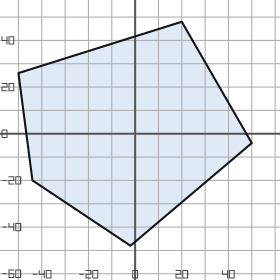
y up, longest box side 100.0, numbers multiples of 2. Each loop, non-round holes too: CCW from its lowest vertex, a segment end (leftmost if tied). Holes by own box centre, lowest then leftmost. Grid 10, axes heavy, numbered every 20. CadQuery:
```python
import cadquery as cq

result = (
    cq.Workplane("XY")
    .moveTo(-2.0, -48.0)
    .lineTo(50.0, -4.0)
    .lineTo(20.0, 48.0)
    .lineTo(-50.0, 26.0)
    .lineTo(-44.0, -20.0)
    .close()
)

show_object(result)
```